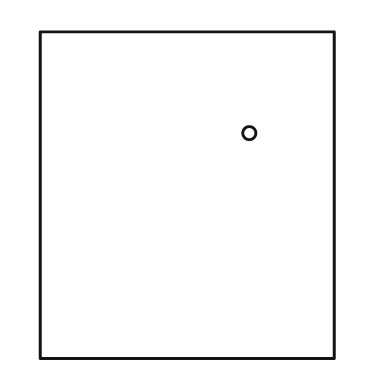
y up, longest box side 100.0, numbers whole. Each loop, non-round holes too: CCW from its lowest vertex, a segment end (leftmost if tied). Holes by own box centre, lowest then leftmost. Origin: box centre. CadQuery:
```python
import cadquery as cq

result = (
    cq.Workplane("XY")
    .moveTo(-45.0, -50.0)
    .lineTo(45.0, -50.0)
    .lineTo(45.0, 50.0)
    .lineTo(-45.0, 50.0)
    .close()
    .moveTo(19.0, 19.0)
    .circle(2.0)
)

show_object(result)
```